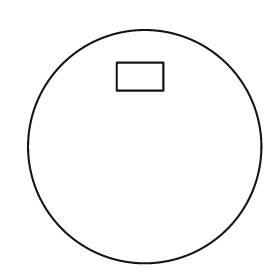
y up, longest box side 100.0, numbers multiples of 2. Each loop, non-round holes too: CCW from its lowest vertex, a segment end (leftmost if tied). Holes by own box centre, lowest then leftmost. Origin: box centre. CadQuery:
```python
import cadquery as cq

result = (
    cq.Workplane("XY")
    .moveTo(0.0, 0.0)
    .circle(50.0)
    .moveTo(-12.0, 24.0)
    .lineTo(8.0, 24.0)
    .lineTo(8.0, 36.0)
    .lineTo(-12.0, 36.0)
    .close()
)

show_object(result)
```